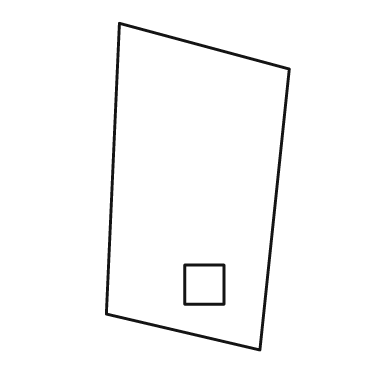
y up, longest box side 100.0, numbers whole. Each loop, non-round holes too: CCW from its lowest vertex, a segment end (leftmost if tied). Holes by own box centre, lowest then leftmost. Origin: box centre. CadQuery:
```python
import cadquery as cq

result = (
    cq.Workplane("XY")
    .moveTo(19.0, -50.0)
    .lineTo(28.0, 36.0)
    .lineTo(-24.0, 50.0)
    .lineTo(-28.0, -39.0)
    .close()
    .moveTo(-4.0, -36.0)
    .lineTo(8.0, -36.0)
    .lineTo(8.0, -24.0)
    .lineTo(-4.0, -24.0)
    .close()
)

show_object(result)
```